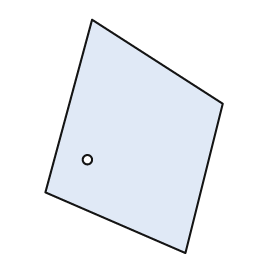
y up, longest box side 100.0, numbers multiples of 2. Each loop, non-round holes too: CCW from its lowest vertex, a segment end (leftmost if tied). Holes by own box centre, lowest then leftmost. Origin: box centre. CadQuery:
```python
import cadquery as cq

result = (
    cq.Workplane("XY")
    .moveTo(22.0, -50.0)
    .lineTo(38.0, 14.0)
    .lineTo(-18.0, 50.0)
    .lineTo(-38.0, -24.0)
    .close()
    .moveTo(-20.0, -10.0)
    .circle(2.0)
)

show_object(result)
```